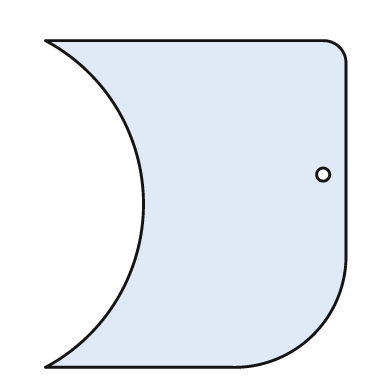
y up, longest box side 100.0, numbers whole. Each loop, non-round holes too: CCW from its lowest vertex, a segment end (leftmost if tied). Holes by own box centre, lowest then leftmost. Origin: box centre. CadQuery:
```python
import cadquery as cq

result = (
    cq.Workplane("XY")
    .moveTo(-46.0, -50.0)
    .lineTo(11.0, -50.0)
    .threePointArc((36.0, -40.0), (46.0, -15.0))
    .lineTo(46.0, 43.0)
    .threePointArc((44.0, 48.0), (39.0, 50.0))
    .lineTo(-46.0, 50.0)
    .threePointArc((-16.0, 0.0), (-46.0, -50.0))
    .close()
    .moveTo(39.0, 9.0)
    .circle(2.0)
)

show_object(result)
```